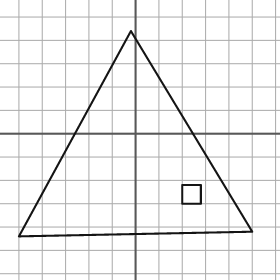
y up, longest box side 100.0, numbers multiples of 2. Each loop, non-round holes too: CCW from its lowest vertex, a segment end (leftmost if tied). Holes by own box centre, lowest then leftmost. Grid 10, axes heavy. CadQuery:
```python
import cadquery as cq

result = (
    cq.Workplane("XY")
    .moveTo(-50.0, -44.0)
    .lineTo(50.0, -42.0)
    .lineTo(-2.0, 44.0)
    .close()
    .moveTo(20.0, -30.0)
    .lineTo(28.0, -30.0)
    .lineTo(28.0, -22.0)
    .lineTo(20.0, -22.0)
    .close()
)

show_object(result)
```